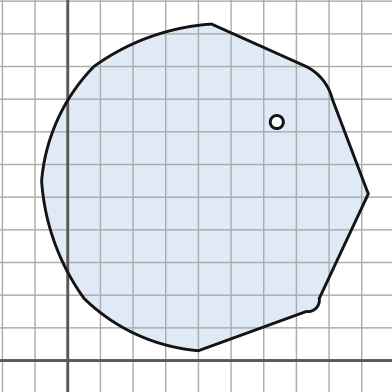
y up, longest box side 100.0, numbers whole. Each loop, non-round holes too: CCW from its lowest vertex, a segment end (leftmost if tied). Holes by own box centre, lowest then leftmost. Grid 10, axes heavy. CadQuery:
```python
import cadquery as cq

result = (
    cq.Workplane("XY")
    .moveTo(40.0, 3.0)
    .lineTo(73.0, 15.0)
    .threePointArc((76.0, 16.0), (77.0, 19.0))
    .lineTo(92.0, 51.0)
    .lineTo(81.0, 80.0)
    .threePointArc((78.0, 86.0), (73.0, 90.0))
    .lineTo(44.0, 103.0)
    .threePointArc((25.0, 99.0), (8.0, 90.0))
    .threePointArc((-3.0, 74.0), (-8.0, 55.0))
    .threePointArc((-4.0, 36.0), (5.0, 19.0))
    .threePointArc((21.0, 8.0), (40.0, 3.0))
    .close()
    .moveTo(64.0, 73.0)
    .circle(2.0)
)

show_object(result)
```